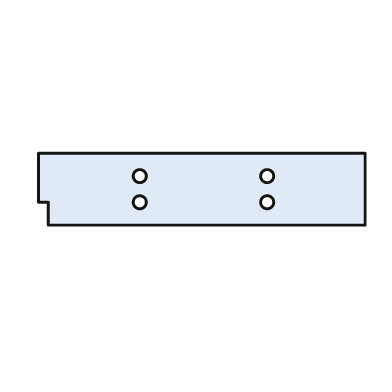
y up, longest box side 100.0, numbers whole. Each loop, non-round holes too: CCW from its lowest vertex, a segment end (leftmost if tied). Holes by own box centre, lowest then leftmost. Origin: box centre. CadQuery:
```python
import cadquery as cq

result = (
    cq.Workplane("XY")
    .moveTo(-47.0, -11.0)
    .lineTo(50.0, -11.0)
    .lineTo(50.0, 11.0)
    .lineTo(-50.0, 11.0)
    .lineTo(-50.0, -4.0)
    .lineTo(-47.0, -4.0)
    .close()
    .moveTo(-19.0, -4.0)
    .circle(2.0)
    .moveTo(20.0, -4.0)
    .circle(2.0)
    .moveTo(-19.0, 4.0)
    .circle(2.0)
    .moveTo(20.0, 4.0)
    .circle(2.0)
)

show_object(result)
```